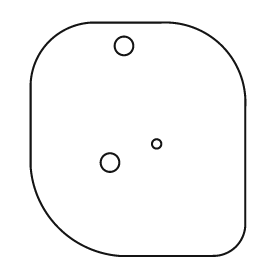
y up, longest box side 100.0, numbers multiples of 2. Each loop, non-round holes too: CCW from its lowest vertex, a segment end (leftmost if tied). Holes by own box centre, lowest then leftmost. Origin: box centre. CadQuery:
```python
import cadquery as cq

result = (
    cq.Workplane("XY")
    .moveTo(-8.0, -50.0)
    .lineTo(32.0, -50.0)
    .threePointArc((42.0, -46.0), (46.0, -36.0))
    .lineTo(46.0, 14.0)
    .threePointArc((36.0, 40.0), (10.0, 50.0))
    .lineTo(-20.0, 50.0)
    .threePointArc((-38.0, 42.0), (-46.0, 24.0))
    .lineTo(-46.0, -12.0)
    .threePointArc((-34.0, -38.0), (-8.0, -50.0))
    .close()
    .moveTo(-12.0, -10.0)
    .circle(4.0)
    .moveTo(8.0, -2.0)
    .circle(2.0)
    .moveTo(-6.0, 40.0)
    .circle(4.0)
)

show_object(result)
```